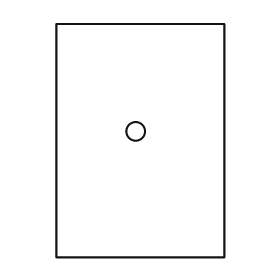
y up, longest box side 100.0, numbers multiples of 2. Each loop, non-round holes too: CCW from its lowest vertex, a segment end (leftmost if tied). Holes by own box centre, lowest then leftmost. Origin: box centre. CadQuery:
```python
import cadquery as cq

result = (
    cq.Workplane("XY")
    .moveTo(-36.0, -50.0)
    .lineTo(36.0, -50.0)
    .lineTo(36.0, 50.0)
    .lineTo(-36.0, 50.0)
    .close()
    .moveTo(-2.0, 4.0)
    .circle(4.0)
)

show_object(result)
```